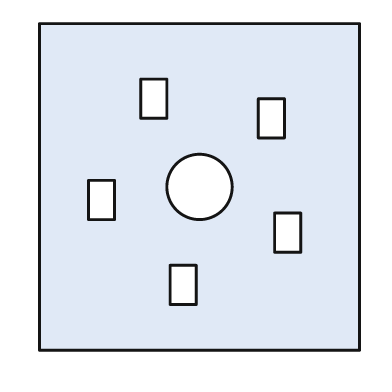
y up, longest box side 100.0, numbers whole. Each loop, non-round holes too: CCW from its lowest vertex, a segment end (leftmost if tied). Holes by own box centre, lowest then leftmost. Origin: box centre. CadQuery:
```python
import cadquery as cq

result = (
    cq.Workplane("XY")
    .moveTo(-49.0, -50.0)
    .lineTo(49.0, -50.0)
    .lineTo(49.0, 50.0)
    .lineTo(-49.0, 50.0)
    .close()
    .moveTo(-9.0, -36.0)
    .lineTo(-1.0, -36.0)
    .lineTo(-1.0, -24.0)
    .lineTo(-9.0, -24.0)
    .close()
    .moveTo(23.0, -20.0)
    .lineTo(31.0, -20.0)
    .lineTo(31.0, -8.0)
    .lineTo(23.0, -8.0)
    .close()
    .moveTo(-34.0, -10.0)
    .lineTo(-26.0, -10.0)
    .lineTo(-26.0, 2.0)
    .lineTo(-34.0, 2.0)
    .close()
    .moveTo(0.0, 0.0)
    .circle(10.0)
    .moveTo(18.0, 15.0)
    .lineTo(26.0, 15.0)
    .lineTo(26.0, 27.0)
    .lineTo(18.0, 27.0)
    .close()
    .moveTo(-18.0, 21.0)
    .lineTo(-10.0, 21.0)
    .lineTo(-10.0, 33.0)
    .lineTo(-18.0, 33.0)
    .close()
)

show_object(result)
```